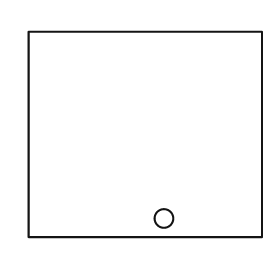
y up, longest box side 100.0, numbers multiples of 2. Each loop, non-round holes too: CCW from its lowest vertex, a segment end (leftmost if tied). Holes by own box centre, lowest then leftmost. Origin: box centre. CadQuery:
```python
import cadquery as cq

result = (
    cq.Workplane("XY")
    .moveTo(-50.0, -44.0)
    .lineTo(50.0, -44.0)
    .lineTo(50.0, 44.0)
    .lineTo(-50.0, 44.0)
    .close()
    .moveTo(8.0, -36.0)
    .circle(4.0)
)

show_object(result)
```